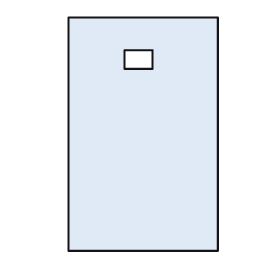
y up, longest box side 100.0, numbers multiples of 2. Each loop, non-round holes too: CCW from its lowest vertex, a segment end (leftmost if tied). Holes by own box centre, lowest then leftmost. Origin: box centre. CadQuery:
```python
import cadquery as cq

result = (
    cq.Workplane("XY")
    .moveTo(-32.0, -50.0)
    .lineTo(32.0, -50.0)
    .lineTo(32.0, 50.0)
    .lineTo(-32.0, 50.0)
    .close()
    .moveTo(-8.0, 28.0)
    .lineTo(4.0, 28.0)
    .lineTo(4.0, 36.0)
    .lineTo(-8.0, 36.0)
    .close()
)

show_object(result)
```